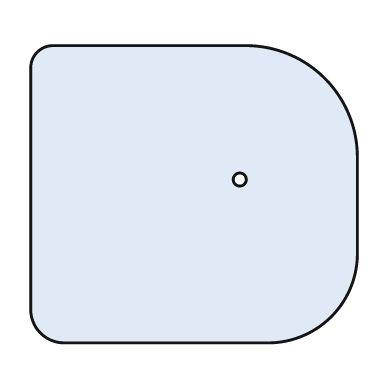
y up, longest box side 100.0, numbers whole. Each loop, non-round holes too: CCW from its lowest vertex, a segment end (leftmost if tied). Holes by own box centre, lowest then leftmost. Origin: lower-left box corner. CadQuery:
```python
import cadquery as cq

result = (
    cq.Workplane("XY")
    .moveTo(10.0, 0.0)
    .lineTo(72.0, 0.0)
    .threePointArc((92.0, 8.0), (100.0, 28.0))
    .lineTo(100.0, 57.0)
    .threePointArc((90.0, 81.0), (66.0, 91.0))
    .lineTo(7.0, 91.0)
    .threePointArc((2.0, 89.0), (0.0, 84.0))
    .lineTo(0.0, 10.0)
    .threePointArc((3.0, 3.0), (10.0, 0.0))
    .close()
    .moveTo(64.0, 50.0)
    .circle(2.0)
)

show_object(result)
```